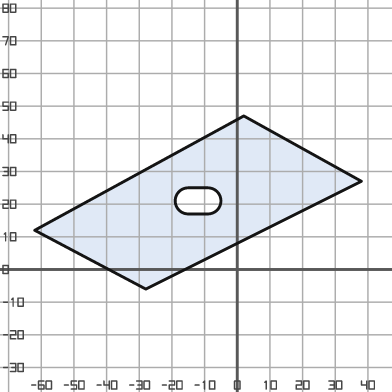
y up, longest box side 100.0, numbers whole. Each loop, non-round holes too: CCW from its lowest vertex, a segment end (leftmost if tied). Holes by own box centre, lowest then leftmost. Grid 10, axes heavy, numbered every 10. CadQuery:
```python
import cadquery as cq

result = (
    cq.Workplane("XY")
    .moveTo(-28.0, -6.0)
    .lineTo(38.0, 27.0)
    .lineTo(2.0, 47.0)
    .lineTo(-62.0, 12.0)
    .close()
    .moveTo(-15.0, 17.0)
    .lineTo(-9.0, 17.0)
    .threePointArc((-5.0, 21.0), (-9.0, 25.0))
    .lineTo(-15.0, 25.0)
    .threePointArc((-19.0, 21.0), (-15.0, 17.0))
    .close()
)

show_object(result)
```